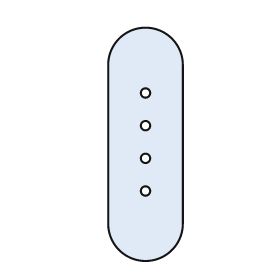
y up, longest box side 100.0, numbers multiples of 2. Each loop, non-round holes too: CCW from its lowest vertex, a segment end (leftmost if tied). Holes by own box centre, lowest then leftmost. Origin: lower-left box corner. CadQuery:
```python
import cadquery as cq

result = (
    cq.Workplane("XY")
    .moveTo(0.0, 16.0)
    .threePointArc((16.0, 0.0), (32.0, 16.0))
    .lineTo(32.0, 84.0)
    .threePointArc((16.0, 100.0), (0.0, 84.0))
    .close()
    .moveTo(16.0, 30.0)
    .circle(2.0)
    .moveTo(16.0, 44.0)
    .circle(2.0)
    .moveTo(16.0, 58.0)
    .circle(2.0)
    .moveTo(16.0, 72.0)
    .circle(2.0)
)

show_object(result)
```